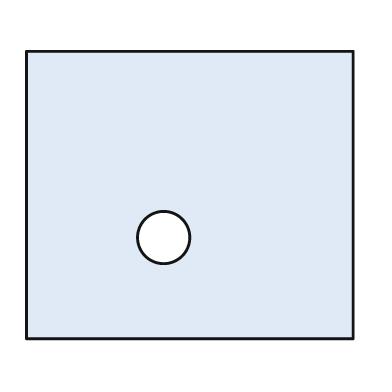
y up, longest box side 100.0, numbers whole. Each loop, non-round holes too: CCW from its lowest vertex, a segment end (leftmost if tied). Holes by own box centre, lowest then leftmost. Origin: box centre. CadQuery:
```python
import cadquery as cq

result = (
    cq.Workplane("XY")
    .moveTo(-50.0, -44.0)
    .lineTo(50.0, -44.0)
    .lineTo(50.0, 44.0)
    .lineTo(-50.0, 44.0)
    .close()
    .moveTo(-8.0, -13.0)
    .circle(8.0)
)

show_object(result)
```